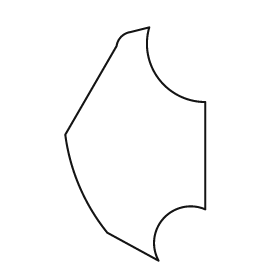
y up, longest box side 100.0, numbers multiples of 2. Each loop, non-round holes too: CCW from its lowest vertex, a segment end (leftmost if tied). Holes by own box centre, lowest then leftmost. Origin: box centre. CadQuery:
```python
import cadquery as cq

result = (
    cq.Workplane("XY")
    .moveTo(10.0, -50.0)
    .threePointArc((12.0, -32.0), (30.0, -28.0))
    .lineTo(30.0, 18.0)
    .threePointArc((10.0, 28.0), (6.0, 50.0))
    .lineTo(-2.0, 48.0)
    .threePointArc((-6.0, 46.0), (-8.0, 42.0))
    .lineTo(-30.0, 4.0)
    .threePointArc((-24.0, -18.0), (-12.0, -38.0))
    .close()
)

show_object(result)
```